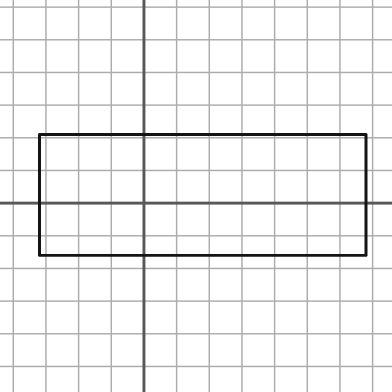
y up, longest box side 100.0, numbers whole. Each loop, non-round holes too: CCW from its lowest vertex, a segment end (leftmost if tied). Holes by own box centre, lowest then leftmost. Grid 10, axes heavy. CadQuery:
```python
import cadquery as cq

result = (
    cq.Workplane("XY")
    .moveTo(-32.0, -16.0)
    .lineTo(68.0, -16.0)
    .lineTo(68.0, 21.0)
    .lineTo(-32.0, 21.0)
    .close()
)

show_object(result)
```